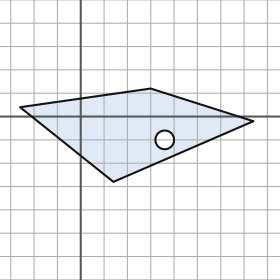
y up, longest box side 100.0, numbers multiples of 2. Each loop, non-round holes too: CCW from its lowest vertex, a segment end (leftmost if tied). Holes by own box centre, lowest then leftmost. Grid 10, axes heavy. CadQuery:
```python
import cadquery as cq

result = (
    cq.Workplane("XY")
    .moveTo(14.0, -28.0)
    .lineTo(74.0, -2.0)
    .lineTo(30.0, 12.0)
    .lineTo(-26.0, 4.0)
    .close()
    .moveTo(36.0, -10.0)
    .circle(4.0)
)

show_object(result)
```